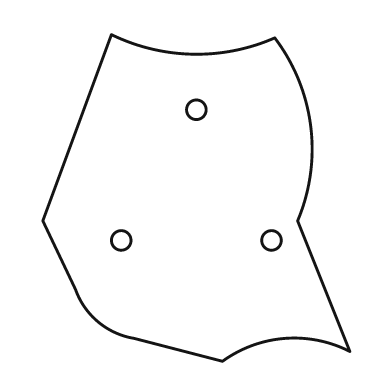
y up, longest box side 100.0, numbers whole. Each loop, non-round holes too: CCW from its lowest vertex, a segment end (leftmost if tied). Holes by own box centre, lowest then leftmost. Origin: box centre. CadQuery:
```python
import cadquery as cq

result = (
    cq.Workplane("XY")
    .moveTo(8.0, -50.0)
    .threePointArc((27.0, -43.0), (47.0, -47.0))
    .lineTo(31.0, -7.0)
    .threePointArc((35.0, 22.0), (24.0, 49.0))
    .threePointArc((-1.0, 44.0), (-26.0, 50.0))
    .lineTo(-47.0, -7.0)
    .lineTo(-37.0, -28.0)
    .threePointArc((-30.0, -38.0), (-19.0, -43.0))
    .close()
    .moveTo(-23.0, -13.0)
    .circle(3.0)
    .moveTo(23.0, -13.0)
    .circle(3.0)
    .moveTo(0.0, 27.0)
    .circle(3.0)
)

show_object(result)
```